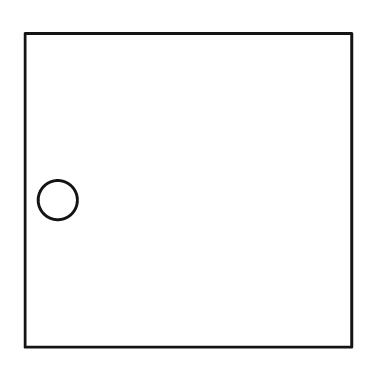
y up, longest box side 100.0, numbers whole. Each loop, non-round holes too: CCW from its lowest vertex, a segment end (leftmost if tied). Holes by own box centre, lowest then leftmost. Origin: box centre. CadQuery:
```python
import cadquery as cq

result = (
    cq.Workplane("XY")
    .moveTo(-50.0, -48.0)
    .lineTo(50.0, -48.0)
    .lineTo(50.0, 48.0)
    .lineTo(-50.0, 48.0)
    .close()
    .moveTo(-40.0, -3.0)
    .circle(6.0)
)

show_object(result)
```